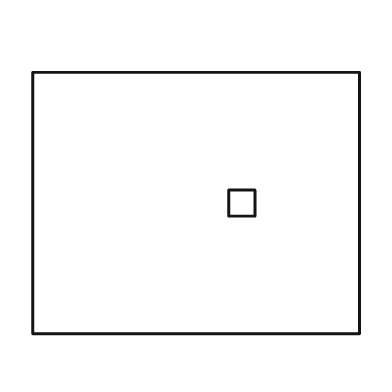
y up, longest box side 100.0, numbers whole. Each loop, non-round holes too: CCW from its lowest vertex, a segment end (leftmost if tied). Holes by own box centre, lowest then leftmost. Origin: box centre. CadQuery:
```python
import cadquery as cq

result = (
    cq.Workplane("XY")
    .moveTo(-50.0, -40.0)
    .lineTo(50.0, -40.0)
    .lineTo(50.0, 40.0)
    .lineTo(-50.0, 40.0)
    .close()
    .moveTo(10.0, -4.0)
    .lineTo(18.0, -4.0)
    .lineTo(18.0, 4.0)
    .lineTo(10.0, 4.0)
    .close()
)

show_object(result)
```